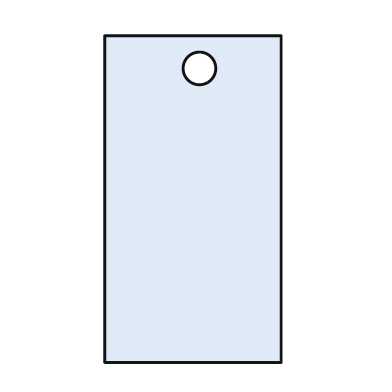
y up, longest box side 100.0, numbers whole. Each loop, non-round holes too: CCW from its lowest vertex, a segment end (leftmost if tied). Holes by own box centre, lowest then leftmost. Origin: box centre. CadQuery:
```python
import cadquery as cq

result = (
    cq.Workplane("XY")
    .moveTo(-27.0, -50.0)
    .lineTo(27.0, -50.0)
    .lineTo(27.0, 50.0)
    .lineTo(-27.0, 50.0)
    .close()
    .moveTo(2.0, 40.0)
    .circle(5.0)
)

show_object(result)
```